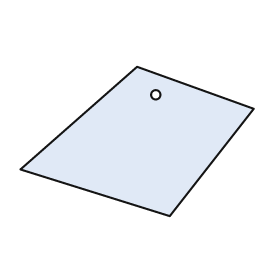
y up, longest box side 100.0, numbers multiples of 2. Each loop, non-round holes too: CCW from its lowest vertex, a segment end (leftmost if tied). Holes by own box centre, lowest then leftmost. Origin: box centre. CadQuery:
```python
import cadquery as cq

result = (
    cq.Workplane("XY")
    .moveTo(14.0, -32.0)
    .lineTo(50.0, 14.0)
    .lineTo(0.0, 32.0)
    .lineTo(-50.0, -12.0)
    .close()
    .moveTo(8.0, 20.0)
    .circle(2.0)
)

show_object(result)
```